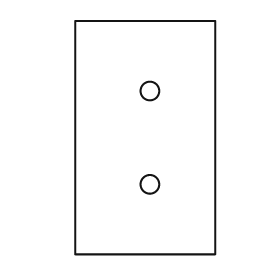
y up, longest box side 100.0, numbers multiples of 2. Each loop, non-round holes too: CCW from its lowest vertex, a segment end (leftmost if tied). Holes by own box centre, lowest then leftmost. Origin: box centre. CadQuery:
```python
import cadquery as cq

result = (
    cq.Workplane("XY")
    .moveTo(-30.0, -50.0)
    .lineTo(30.0, -50.0)
    .lineTo(30.0, 50.0)
    .lineTo(-30.0, 50.0)
    .close()
    .moveTo(2.0, -20.0)
    .circle(4.0)
    .moveTo(2.0, 20.0)
    .circle(4.0)
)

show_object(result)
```